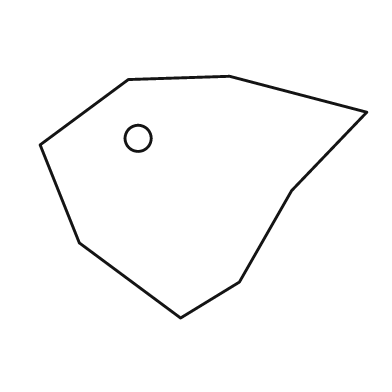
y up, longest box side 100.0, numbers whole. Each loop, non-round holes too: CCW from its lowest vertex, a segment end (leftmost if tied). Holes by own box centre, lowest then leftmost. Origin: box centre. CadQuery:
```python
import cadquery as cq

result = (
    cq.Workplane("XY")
    .moveTo(-7.0, -37.0)
    .lineTo(11.0, -26.0)
    .lineTo(27.0, 2.0)
    .lineTo(50.0, 26.0)
    .lineTo(8.0, 37.0)
    .lineTo(-23.0, 36.0)
    .lineTo(-50.0, 16.0)
    .lineTo(-38.0, -14.0)
    .close()
    .moveTo(-20.0, 18.0)
    .circle(4.0)
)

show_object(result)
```